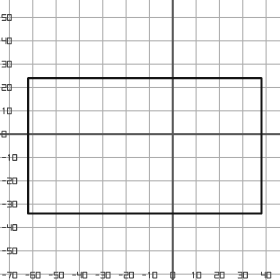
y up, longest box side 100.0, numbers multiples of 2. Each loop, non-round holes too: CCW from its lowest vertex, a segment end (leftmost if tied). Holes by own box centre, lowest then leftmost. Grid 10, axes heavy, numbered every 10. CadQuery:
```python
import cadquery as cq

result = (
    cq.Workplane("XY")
    .moveTo(-62.0, -34.0)
    .lineTo(38.0, -34.0)
    .lineTo(38.0, 24.0)
    .lineTo(-62.0, 24.0)
    .close()
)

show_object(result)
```